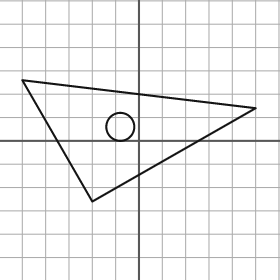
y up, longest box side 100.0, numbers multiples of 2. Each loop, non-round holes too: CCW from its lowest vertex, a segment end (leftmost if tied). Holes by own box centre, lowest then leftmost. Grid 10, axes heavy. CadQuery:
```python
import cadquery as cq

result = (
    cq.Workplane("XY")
    .moveTo(-20.0, -26.0)
    .lineTo(50.0, 14.0)
    .lineTo(-50.0, 26.0)
    .close()
    .moveTo(-8.0, 6.0)
    .circle(6.0)
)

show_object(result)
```